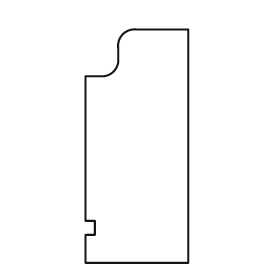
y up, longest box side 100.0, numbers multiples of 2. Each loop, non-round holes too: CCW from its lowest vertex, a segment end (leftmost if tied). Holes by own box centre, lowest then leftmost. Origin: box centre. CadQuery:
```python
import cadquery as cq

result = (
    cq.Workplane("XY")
    .moveTo(-22.0, -50.0)
    .lineTo(22.0, -50.0)
    .lineTo(22.0, 50.0)
    .lineTo(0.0, 50.0)
    .threePointArc((-6.0, 48.0), (-8.0, 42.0))
    .lineTo(-8.0, 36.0)
    .threePointArc((-10.0, 32.0), (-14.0, 30.0))
    .lineTo(-22.0, 30.0)
    .lineTo(-22.0, -32.0)
    .lineTo(-18.0, -32.0)
    .lineTo(-18.0, -38.0)
    .lineTo(-22.0, -38.0)
    .close()
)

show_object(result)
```